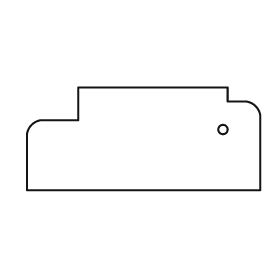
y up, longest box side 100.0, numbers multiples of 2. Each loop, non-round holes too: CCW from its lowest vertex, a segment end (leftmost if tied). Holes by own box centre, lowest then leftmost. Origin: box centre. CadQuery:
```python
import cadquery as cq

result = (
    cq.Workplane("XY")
    .moveTo(-50.0, -22.0)
    .lineTo(50.0, -22.0)
    .lineTo(50.0, 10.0)
    .threePointArc((48.0, 14.0), (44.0, 16.0))
    .lineTo(36.0, 16.0)
    .lineTo(36.0, 22.0)
    .lineTo(-28.0, 22.0)
    .lineTo(-28.0, 8.0)
    .lineTo(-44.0, 8.0)
    .threePointArc((-48.0, 6.0), (-50.0, 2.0))
    .close()
    .moveTo(34.0, 4.0)
    .circle(2.0)
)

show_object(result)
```